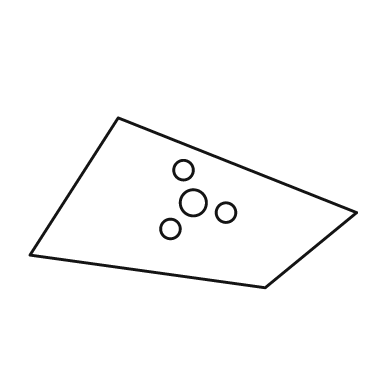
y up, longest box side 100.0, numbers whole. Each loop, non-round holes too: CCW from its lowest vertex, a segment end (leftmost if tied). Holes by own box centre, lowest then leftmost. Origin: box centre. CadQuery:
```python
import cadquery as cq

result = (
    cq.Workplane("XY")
    .moveTo(22.0, -26.0)
    .lineTo(50.0, -3.0)
    .lineTo(-23.0, 26.0)
    .lineTo(-50.0, -16.0)
    .close()
    .moveTo(-7.0, -8.0)
    .circle(3.0)
    .moveTo(10.0, -3.0)
    .circle(3.0)
    .moveTo(0.0, 0.0)
    .circle(4.0)
    .moveTo(-3.0, 10.0)
    .circle(3.0)
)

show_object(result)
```